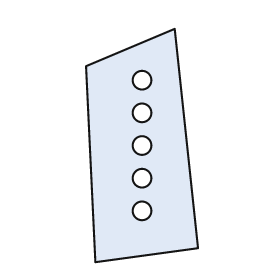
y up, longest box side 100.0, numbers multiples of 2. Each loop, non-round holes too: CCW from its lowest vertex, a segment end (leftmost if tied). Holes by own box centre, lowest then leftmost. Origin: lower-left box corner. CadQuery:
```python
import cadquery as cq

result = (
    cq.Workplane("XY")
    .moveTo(4.0, 0.0)
    .lineTo(48.0, 6.0)
    .lineTo(38.0, 100.0)
    .lineTo(0.0, 84.0)
    .close()
    .moveTo(24.0, 22.0)
    .circle(4.0)
    .moveTo(24.0, 36.0)
    .circle(4.0)
    .moveTo(24.0, 50.0)
    .circle(4.0)
    .moveTo(24.0, 64.0)
    .circle(4.0)
    .moveTo(24.0, 78.0)
    .circle(4.0)
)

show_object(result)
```